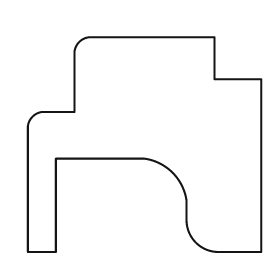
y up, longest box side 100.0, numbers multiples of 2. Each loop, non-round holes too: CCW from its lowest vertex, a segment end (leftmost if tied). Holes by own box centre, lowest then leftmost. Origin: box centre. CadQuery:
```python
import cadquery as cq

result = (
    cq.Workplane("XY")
    .moveTo(-50.0, -46.0)
    .lineTo(-38.0, -46.0)
    .lineTo(-38.0, -6.0)
    .lineTo(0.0, -6.0)
    .threePointArc((12.0, -12.0), (18.0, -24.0))
    .lineTo(18.0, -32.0)
    .threePointArc((22.0, -42.0), (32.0, -46.0))
    .lineTo(50.0, -46.0)
    .lineTo(50.0, 28.0)
    .lineTo(30.0, 28.0)
    .lineTo(30.0, 46.0)
    .lineTo(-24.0, 46.0)
    .threePointArc((-28.0, 44.0), (-30.0, 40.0))
    .lineTo(-30.0, 14.0)
    .lineTo(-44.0, 14.0)
    .threePointArc((-48.0, 12.0), (-50.0, 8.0))
    .close()
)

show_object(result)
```